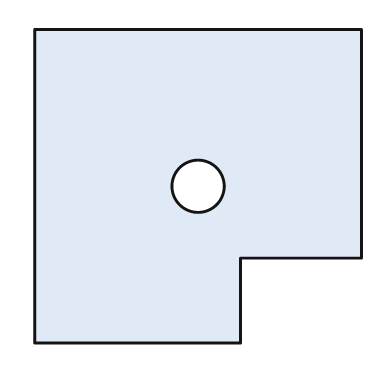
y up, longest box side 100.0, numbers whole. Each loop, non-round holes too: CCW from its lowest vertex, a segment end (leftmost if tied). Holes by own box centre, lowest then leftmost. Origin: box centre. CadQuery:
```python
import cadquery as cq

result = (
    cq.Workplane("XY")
    .moveTo(-50.0, -48.0)
    .lineTo(13.0, -48.0)
    .lineTo(13.0, -22.0)
    .lineTo(50.0, -22.0)
    .lineTo(50.0, 48.0)
    .lineTo(-50.0, 48.0)
    .close()
    .moveTo(0.0, 0.0)
    .circle(8.0)
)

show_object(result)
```